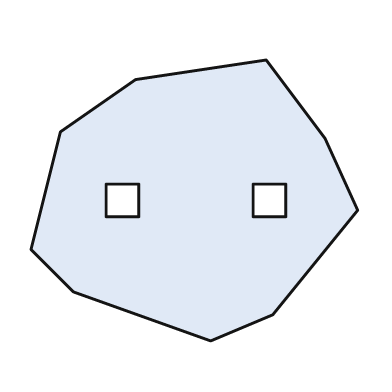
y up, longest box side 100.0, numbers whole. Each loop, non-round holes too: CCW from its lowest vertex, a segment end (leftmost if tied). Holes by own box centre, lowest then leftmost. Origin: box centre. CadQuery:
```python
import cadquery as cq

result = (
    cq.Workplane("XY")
    .moveTo(5.0, -43.0)
    .lineTo(24.0, -35.0)
    .lineTo(50.0, -3.0)
    .lineTo(40.0, 19.0)
    .lineTo(22.0, 43.0)
    .lineTo(-18.0, 37.0)
    .lineTo(-41.0, 21.0)
    .lineTo(-50.0, -15.0)
    .lineTo(-37.0, -28.0)
    .close()
    .moveTo(-27.0, -5.0)
    .lineTo(-17.0, -5.0)
    .lineTo(-17.0, 5.0)
    .lineTo(-27.0, 5.0)
    .close()
    .moveTo(18.0, -5.0)
    .lineTo(28.0, -5.0)
    .lineTo(28.0, 5.0)
    .lineTo(18.0, 5.0)
    .close()
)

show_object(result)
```